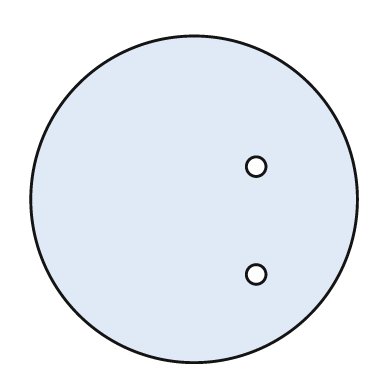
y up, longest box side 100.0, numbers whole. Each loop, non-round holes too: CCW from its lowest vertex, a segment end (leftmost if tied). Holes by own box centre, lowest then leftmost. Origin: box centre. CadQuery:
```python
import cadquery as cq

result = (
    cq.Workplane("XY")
    .moveTo(0.0, 0.0)
    .circle(50.0)
    .moveTo(19.0, -23.0)
    .circle(3.0)
    .moveTo(19.0, 10.0)
    .circle(3.0)
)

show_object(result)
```